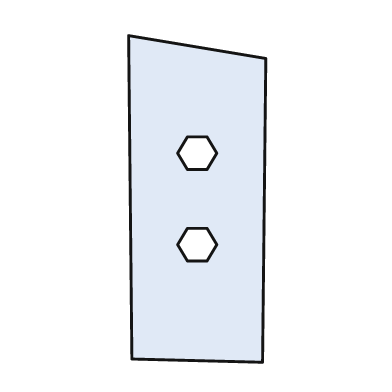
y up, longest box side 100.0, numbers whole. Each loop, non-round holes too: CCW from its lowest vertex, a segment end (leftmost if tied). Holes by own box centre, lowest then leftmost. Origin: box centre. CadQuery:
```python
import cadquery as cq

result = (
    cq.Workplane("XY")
    .moveTo(20.0, -50.0)
    .lineTo(21.0, 43.0)
    .lineTo(-21.0, 50.0)
    .lineTo(-20.0, -49.0)
    .close()
    .moveTo(-3.0, -19.0)
    .lineTo(3.0, -19.0)
    .lineTo(6.0, -14.0)
    .lineTo(3.0, -9.0)
    .lineTo(-3.0, -9.0)
    .lineTo(-6.0, -14.0)
    .close()
    .moveTo(-3.0, 9.0)
    .lineTo(3.0, 9.0)
    .lineTo(6.0, 14.0)
    .lineTo(3.0, 19.0)
    .lineTo(-3.0, 19.0)
    .lineTo(-6.0, 14.0)
    .close()
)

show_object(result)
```